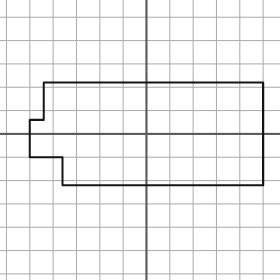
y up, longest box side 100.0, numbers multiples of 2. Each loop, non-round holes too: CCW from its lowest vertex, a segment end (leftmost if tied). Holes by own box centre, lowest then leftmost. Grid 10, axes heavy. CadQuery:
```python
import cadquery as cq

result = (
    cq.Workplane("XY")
    .moveTo(-36.0, -22.0)
    .lineTo(50.0, -22.0)
    .lineTo(50.0, 22.0)
    .lineTo(-44.0, 22.0)
    .lineTo(-44.0, 6.0)
    .lineTo(-50.0, 6.0)
    .lineTo(-50.0, -10.0)
    .lineTo(-36.0, -10.0)
    .close()
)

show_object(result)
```